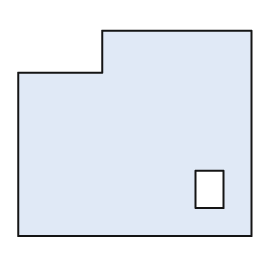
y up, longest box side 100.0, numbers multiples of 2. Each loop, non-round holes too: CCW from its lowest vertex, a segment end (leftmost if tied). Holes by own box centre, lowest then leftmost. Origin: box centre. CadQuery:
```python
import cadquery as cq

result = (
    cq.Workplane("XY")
    .moveTo(-50.0, -44.0)
    .lineTo(50.0, -44.0)
    .lineTo(50.0, 44.0)
    .lineTo(-14.0, 44.0)
    .lineTo(-14.0, 26.0)
    .lineTo(-50.0, 26.0)
    .close()
    .moveTo(26.0, -32.0)
    .lineTo(38.0, -32.0)
    .lineTo(38.0, -16.0)
    .lineTo(26.0, -16.0)
    .close()
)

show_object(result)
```